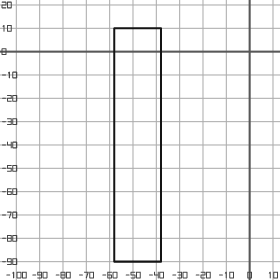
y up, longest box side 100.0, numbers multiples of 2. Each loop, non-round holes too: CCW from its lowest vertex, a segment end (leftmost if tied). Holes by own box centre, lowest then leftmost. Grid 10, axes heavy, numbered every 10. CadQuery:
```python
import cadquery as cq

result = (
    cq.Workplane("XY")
    .moveTo(-58.0, -90.0)
    .lineTo(-38.0, -90.0)
    .lineTo(-38.0, 10.0)
    .lineTo(-58.0, 10.0)
    .close()
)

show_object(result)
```